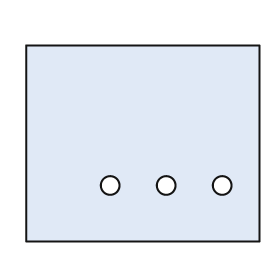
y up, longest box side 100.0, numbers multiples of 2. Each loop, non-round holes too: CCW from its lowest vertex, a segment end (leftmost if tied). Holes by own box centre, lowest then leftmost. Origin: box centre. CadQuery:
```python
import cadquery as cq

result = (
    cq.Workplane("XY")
    .moveTo(-50.0, -42.0)
    .lineTo(50.0, -42.0)
    .lineTo(50.0, 42.0)
    .lineTo(-50.0, 42.0)
    .close()
    .moveTo(-14.0, -18.0)
    .circle(4.0)
    .moveTo(10.0, -18.0)
    .circle(4.0)
    .moveTo(34.0, -18.0)
    .circle(4.0)
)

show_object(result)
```